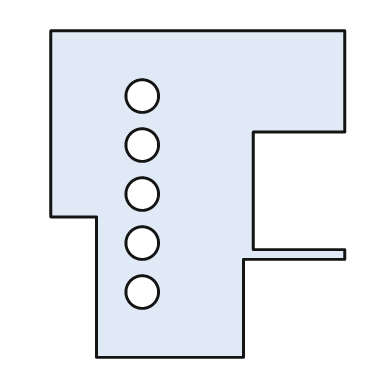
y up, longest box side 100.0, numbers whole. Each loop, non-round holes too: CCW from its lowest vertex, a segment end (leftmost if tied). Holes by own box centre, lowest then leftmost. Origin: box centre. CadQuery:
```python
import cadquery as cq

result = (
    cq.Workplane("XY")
    .moveTo(-31.0, -50.0)
    .lineTo(14.0, -50.0)
    .lineTo(14.0, -20.0)
    .lineTo(45.0, -20.0)
    .lineTo(45.0, -17.0)
    .lineTo(17.0, -17.0)
    .lineTo(17.0, 19.0)
    .lineTo(45.0, 19.0)
    .lineTo(45.0, 50.0)
    .lineTo(-45.0, 50.0)
    .lineTo(-45.0, -7.0)
    .lineTo(-31.0, -7.0)
    .close()
    .moveTo(-17.0, -30.0)
    .circle(5.0)
    .moveTo(-17.0, -15.0)
    .circle(5.0)
    .moveTo(-17.0, 0.0)
    .circle(5.0)
    .moveTo(-17.0, 15.0)
    .circle(5.0)
    .moveTo(-17.0, 30.0)
    .circle(5.0)
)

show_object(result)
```